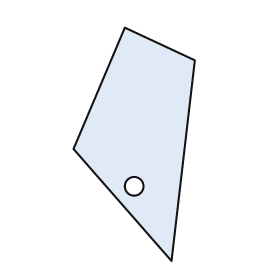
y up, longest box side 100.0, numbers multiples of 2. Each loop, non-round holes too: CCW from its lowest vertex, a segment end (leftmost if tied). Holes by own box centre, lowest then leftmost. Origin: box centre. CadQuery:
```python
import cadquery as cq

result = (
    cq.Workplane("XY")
    .moveTo(16.0, -50.0)
    .lineTo(26.0, 36.0)
    .lineTo(-4.0, 50.0)
    .lineTo(-26.0, -2.0)
    .close()
    .moveTo(0.0, -18.0)
    .circle(4.0)
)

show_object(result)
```